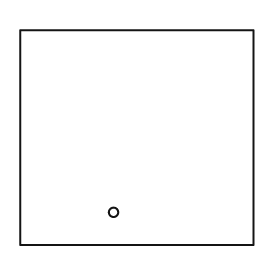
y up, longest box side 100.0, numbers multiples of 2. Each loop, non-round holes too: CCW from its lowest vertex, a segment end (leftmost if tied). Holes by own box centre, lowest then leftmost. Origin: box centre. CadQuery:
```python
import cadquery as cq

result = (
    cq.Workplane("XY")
    .moveTo(-50.0, -46.0)
    .lineTo(50.0, -46.0)
    .lineTo(50.0, 46.0)
    .lineTo(-50.0, 46.0)
    .close()
    .moveTo(-10.0, -32.0)
    .circle(2.0)
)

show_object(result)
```